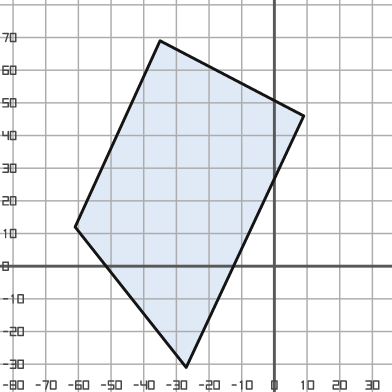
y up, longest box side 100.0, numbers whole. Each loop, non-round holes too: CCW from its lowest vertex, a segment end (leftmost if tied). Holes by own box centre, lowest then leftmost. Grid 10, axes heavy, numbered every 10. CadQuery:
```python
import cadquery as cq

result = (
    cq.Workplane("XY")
    .moveTo(-27.0, -31.0)
    .lineTo(9.0, 46.0)
    .lineTo(-35.0, 69.0)
    .lineTo(-61.0, 12.0)
    .close()
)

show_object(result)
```